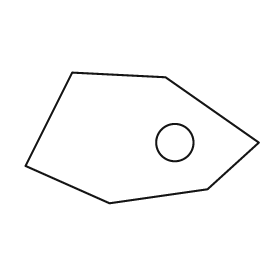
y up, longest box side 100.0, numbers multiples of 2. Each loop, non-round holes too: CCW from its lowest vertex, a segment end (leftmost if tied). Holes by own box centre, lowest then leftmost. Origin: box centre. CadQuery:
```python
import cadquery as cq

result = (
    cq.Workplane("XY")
    .moveTo(-14.0, -28.0)
    .lineTo(28.0, -22.0)
    .lineTo(50.0, -2.0)
    .lineTo(10.0, 26.0)
    .lineTo(-30.0, 28.0)
    .lineTo(-50.0, -12.0)
    .close()
    .moveTo(14.0, -2.0)
    .circle(8.0)
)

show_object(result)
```